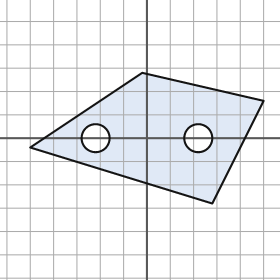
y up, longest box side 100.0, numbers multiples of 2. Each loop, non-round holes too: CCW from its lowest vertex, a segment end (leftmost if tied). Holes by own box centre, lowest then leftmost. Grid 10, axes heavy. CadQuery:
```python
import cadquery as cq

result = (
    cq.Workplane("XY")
    .moveTo(28.0, -28.0)
    .lineTo(50.0, 16.0)
    .lineTo(-2.0, 28.0)
    .lineTo(-50.0, -4.0)
    .close()
    .moveTo(-22.0, 0.0)
    .circle(6.0)
    .moveTo(22.0, 0.0)
    .circle(6.0)
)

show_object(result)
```